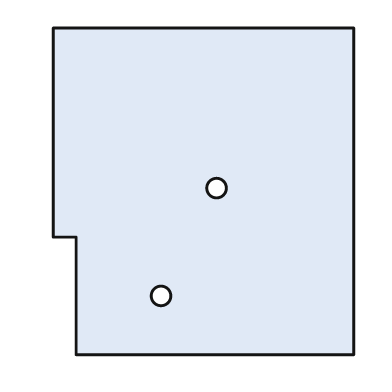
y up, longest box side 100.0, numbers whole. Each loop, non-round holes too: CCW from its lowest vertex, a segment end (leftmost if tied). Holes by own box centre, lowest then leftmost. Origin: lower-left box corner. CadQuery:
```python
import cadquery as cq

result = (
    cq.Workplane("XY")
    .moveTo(7.0, 0.0)
    .lineTo(92.0, 0.0)
    .lineTo(92.0, 100.0)
    .lineTo(0.0, 100.0)
    .lineTo(0.0, 36.0)
    .lineTo(7.0, 36.0)
    .close()
    .moveTo(33.0, 18.0)
    .circle(3.0)
    .moveTo(50.0, 51.0)
    .circle(3.0)
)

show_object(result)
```